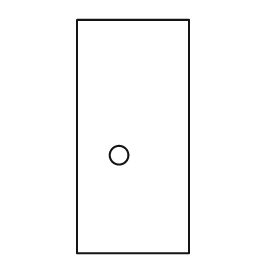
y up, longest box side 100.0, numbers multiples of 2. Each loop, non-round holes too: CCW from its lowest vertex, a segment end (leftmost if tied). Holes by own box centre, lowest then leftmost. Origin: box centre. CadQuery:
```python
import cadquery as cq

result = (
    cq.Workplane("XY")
    .moveTo(-24.0, -50.0)
    .lineTo(24.0, -50.0)
    .lineTo(24.0, 50.0)
    .lineTo(-24.0, 50.0)
    .close()
    .moveTo(-6.0, -8.0)
    .circle(4.0)
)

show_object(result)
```